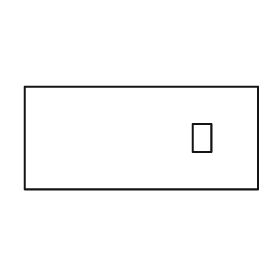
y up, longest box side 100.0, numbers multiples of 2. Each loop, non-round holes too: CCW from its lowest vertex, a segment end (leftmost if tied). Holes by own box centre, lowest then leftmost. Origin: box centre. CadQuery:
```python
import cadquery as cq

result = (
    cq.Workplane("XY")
    .moveTo(-50.0, -22.0)
    .lineTo(50.0, -22.0)
    .lineTo(50.0, 22.0)
    .lineTo(-50.0, 22.0)
    .close()
    .moveTo(22.0, -6.0)
    .lineTo(30.0, -6.0)
    .lineTo(30.0, 6.0)
    .lineTo(22.0, 6.0)
    .close()
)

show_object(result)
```